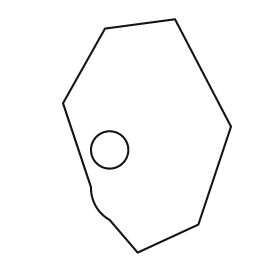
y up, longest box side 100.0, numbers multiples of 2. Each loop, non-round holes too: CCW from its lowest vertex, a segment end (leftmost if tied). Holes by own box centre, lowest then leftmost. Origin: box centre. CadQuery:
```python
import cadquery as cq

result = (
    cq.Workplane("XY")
    .moveTo(-4.0, -50.0)
    .lineTo(22.0, -38.0)
    .lineTo(36.0, 4.0)
    .lineTo(12.0, 50.0)
    .lineTo(-18.0, 46.0)
    .lineTo(-36.0, 14.0)
    .lineTo(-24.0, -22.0)
    .threePointArc((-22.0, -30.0), (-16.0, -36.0))
    .close()
    .moveTo(-16.0, -6.0)
    .circle(8.0)
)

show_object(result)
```